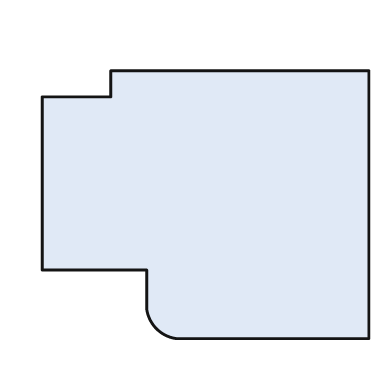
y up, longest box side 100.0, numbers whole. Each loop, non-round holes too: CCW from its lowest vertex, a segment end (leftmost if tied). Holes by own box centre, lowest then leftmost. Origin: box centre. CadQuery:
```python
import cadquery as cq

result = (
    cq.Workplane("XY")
    .moveTo(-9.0, -41.0)
    .lineTo(50.0, -41.0)
    .lineTo(50.0, 41.0)
    .lineTo(-29.0, 41.0)
    .lineTo(-29.0, 33.0)
    .lineTo(-50.0, 33.0)
    .lineTo(-50.0, -20.0)
    .lineTo(-18.0, -20.0)
    .lineTo(-18.0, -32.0)
    .threePointArc((-15.0, -38.0), (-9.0, -41.0))
    .close()
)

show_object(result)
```